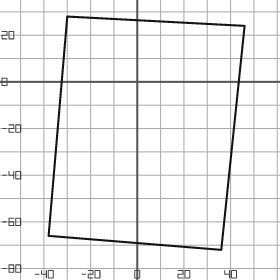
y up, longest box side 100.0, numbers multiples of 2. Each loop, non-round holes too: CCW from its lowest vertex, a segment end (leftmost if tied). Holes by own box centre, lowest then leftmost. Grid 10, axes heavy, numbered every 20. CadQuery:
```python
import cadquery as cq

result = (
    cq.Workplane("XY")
    .moveTo(36.0, -72.0)
    .lineTo(46.0, 24.0)
    .lineTo(-30.0, 28.0)
    .lineTo(-38.0, -66.0)
    .close()
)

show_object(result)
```